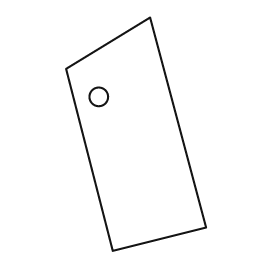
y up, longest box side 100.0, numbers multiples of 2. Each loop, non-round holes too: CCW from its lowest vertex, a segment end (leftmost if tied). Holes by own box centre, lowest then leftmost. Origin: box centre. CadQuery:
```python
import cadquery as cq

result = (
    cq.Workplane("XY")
    .moveTo(-10.0, -50.0)
    .lineTo(30.0, -40.0)
    .lineTo(6.0, 50.0)
    .lineTo(-30.0, 28.0)
    .close()
    .moveTo(-16.0, 16.0)
    .circle(4.0)
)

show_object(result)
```